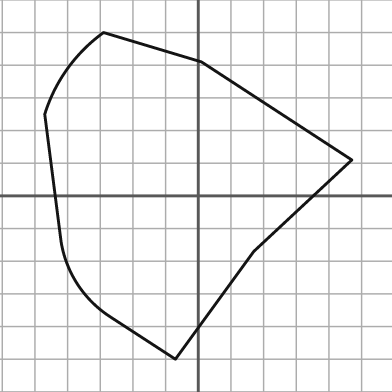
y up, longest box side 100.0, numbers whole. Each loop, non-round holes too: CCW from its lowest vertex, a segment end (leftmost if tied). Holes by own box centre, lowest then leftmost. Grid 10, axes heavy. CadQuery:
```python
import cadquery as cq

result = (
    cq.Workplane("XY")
    .moveTo(-7.0, -50.0)
    .lineTo(17.0, -17.0)
    .lineTo(47.0, 11.0)
    .lineTo(1.0, 41.0)
    .lineTo(-29.0, 50.0)
    .threePointArc((-40.0, 39.0), (-47.0, 25.0))
    .lineTo(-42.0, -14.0)
    .threePointArc((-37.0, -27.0), (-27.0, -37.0))
    .close()
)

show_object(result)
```